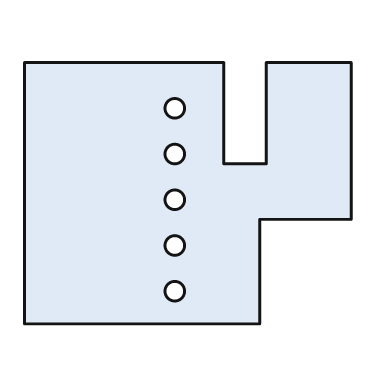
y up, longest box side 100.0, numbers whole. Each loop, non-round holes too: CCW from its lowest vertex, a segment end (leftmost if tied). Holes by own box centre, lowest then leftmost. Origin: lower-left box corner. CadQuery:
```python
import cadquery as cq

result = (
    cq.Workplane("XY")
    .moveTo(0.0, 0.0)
    .lineTo(72.0, 0.0)
    .lineTo(72.0, 32.0)
    .lineTo(100.0, 32.0)
    .lineTo(100.0, 80.0)
    .lineTo(74.0, 80.0)
    .lineTo(74.0, 49.0)
    .lineTo(61.0, 49.0)
    .lineTo(61.0, 80.0)
    .lineTo(0.0, 80.0)
    .close()
    .moveTo(46.0, 10.0)
    .circle(3.0)
    .moveTo(46.0, 24.0)
    .circle(3.0)
    .moveTo(46.0, 38.0)
    .circle(3.0)
    .moveTo(46.0, 52.0)
    .circle(3.0)
    .moveTo(46.0, 66.0)
    .circle(3.0)
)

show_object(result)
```